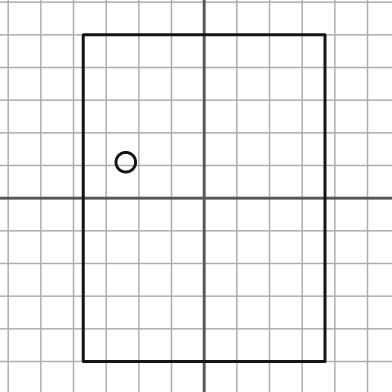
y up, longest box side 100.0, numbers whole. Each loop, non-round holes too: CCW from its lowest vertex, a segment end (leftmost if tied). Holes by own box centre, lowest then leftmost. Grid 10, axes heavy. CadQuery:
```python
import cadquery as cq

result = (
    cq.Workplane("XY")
    .moveTo(-37.0, -50.0)
    .lineTo(37.0, -50.0)
    .lineTo(37.0, 50.0)
    .lineTo(-37.0, 50.0)
    .close()
    .moveTo(-24.0, 11.0)
    .circle(3.0)
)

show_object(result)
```